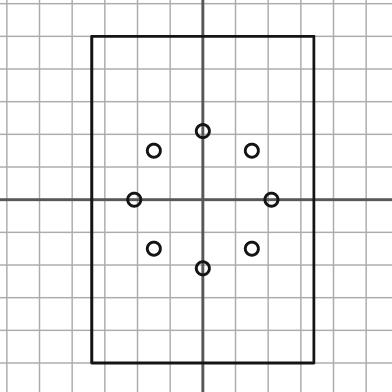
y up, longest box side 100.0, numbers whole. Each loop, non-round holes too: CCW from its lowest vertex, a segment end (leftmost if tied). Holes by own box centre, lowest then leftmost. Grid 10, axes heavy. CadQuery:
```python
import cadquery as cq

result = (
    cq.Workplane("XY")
    .moveTo(-34.0, -50.0)
    .lineTo(34.0, -50.0)
    .lineTo(34.0, 50.0)
    .lineTo(-34.0, 50.0)
    .close()
    .moveTo(0.0, -21.0)
    .circle(2.0)
    .moveTo(-15.0, -15.0)
    .circle(2.0)
    .moveTo(15.0, -15.0)
    .circle(2.0)
    .moveTo(-21.0, 0.0)
    .circle(2.0)
    .moveTo(21.0, 0.0)
    .circle(2.0)
    .moveTo(-15.0, 15.0)
    .circle(2.0)
    .moveTo(15.0, 15.0)
    .circle(2.0)
    .moveTo(0.0, 21.0)
    .circle(2.0)
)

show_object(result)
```